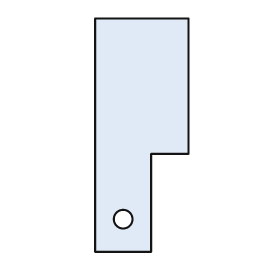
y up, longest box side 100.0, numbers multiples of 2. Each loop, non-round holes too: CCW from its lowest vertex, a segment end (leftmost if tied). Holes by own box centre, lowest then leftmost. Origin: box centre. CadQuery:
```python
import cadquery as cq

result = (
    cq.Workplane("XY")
    .moveTo(-20.0, -50.0)
    .lineTo(4.0, -50.0)
    .lineTo(4.0, -8.0)
    .lineTo(20.0, -8.0)
    .lineTo(20.0, 50.0)
    .lineTo(-20.0, 50.0)
    .close()
    .moveTo(-8.0, -36.0)
    .circle(4.0)
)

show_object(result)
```